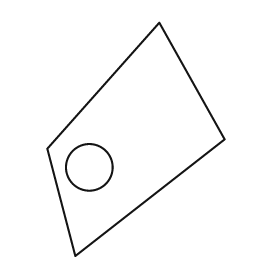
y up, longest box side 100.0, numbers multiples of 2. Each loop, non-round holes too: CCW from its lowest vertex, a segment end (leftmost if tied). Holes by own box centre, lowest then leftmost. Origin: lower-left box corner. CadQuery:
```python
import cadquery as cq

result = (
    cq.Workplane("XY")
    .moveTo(12.0, 0.0)
    .lineTo(76.0, 50.0)
    .lineTo(48.0, 100.0)
    .lineTo(0.0, 46.0)
    .close()
    .moveTo(18.0, 38.0)
    .circle(10.0)
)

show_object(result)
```